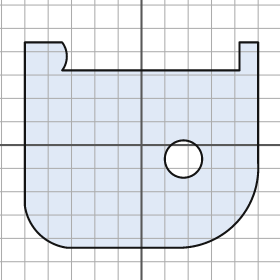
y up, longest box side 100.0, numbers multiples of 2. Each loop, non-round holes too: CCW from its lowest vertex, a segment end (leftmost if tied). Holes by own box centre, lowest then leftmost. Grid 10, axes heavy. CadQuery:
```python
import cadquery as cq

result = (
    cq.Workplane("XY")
    .moveTo(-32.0, -44.0)
    .lineTo(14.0, -44.0)
    .threePointArc((40.0, -34.0), (50.0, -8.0))
    .lineTo(50.0, 44.0)
    .lineTo(42.0, 44.0)
    .lineTo(42.0, 32.0)
    .lineTo(-34.0, 32.0)
    .threePointArc((-32.0, 38.0), (-34.0, 44.0))
    .lineTo(-50.0, 44.0)
    .lineTo(-50.0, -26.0)
    .threePointArc((-44.0, -38.0), (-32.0, -44.0))
    .close()
    .moveTo(18.0, -6.0)
    .circle(8.0)
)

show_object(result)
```